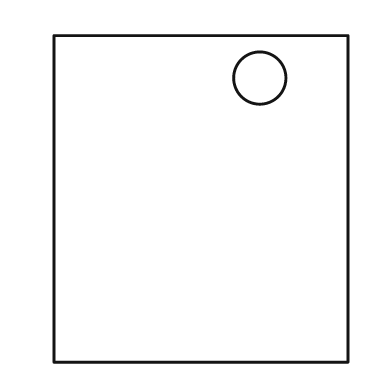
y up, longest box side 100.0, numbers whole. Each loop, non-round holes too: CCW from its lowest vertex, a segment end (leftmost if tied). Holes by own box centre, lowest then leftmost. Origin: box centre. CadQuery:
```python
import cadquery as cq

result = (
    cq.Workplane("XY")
    .moveTo(-45.0, -50.0)
    .lineTo(45.0, -50.0)
    .lineTo(45.0, 50.0)
    .lineTo(-45.0, 50.0)
    .close()
    .moveTo(18.0, 37.0)
    .circle(8.0)
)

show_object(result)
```